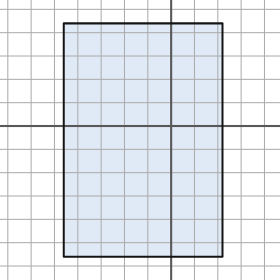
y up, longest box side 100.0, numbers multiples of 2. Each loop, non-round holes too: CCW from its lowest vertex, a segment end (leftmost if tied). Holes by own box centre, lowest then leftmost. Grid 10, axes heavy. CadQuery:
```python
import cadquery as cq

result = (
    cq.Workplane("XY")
    .moveTo(-46.0, -56.0)
    .lineTo(22.0, -56.0)
    .lineTo(22.0, 44.0)
    .lineTo(-46.0, 44.0)
    .close()
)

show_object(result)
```